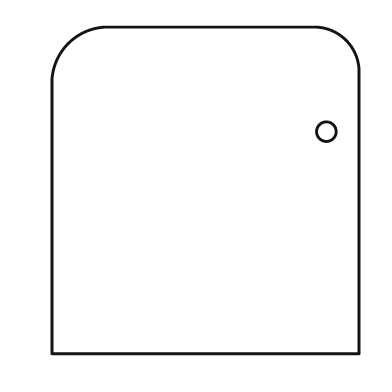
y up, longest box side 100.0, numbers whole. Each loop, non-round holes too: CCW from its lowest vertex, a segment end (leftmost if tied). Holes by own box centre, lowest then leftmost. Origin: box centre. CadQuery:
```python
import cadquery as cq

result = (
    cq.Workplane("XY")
    .moveTo(-47.0, -50.0)
    .lineTo(47.0, -50.0)
    .lineTo(47.0, 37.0)
    .threePointArc((43.0, 46.0), (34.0, 50.0))
    .lineTo(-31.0, 50.0)
    .threePointArc((-42.0, 45.0), (-47.0, 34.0))
    .close()
    .moveTo(37.0, 18.0)
    .circle(3.0)
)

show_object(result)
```